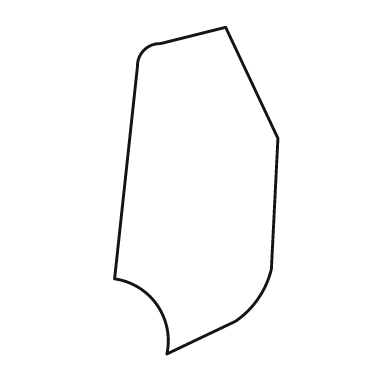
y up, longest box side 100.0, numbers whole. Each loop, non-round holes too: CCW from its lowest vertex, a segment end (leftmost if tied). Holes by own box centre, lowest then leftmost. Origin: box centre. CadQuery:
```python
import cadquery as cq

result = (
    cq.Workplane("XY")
    .moveTo(-9.0, -50.0)
    .lineTo(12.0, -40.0)
    .threePointArc((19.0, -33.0), (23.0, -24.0))
    .lineTo(25.0, 16.0)
    .lineTo(9.0, 50.0)
    .lineTo(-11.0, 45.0)
    .threePointArc((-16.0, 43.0), (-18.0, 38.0))
    .lineTo(-25.0, -27.0)
    .threePointArc((-12.0, -35.0), (-9.0, -50.0))
    .close()
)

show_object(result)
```